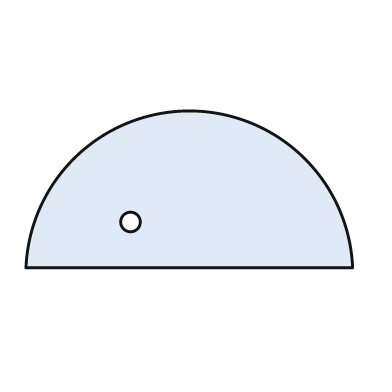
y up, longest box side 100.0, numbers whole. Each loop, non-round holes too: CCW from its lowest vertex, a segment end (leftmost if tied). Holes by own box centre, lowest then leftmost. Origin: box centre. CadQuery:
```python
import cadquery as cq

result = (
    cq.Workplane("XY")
    .moveTo(-50.0, -24.0)
    .lineTo(50.0, -24.0)
    .threePointArc((0.0, 24.0), (-50.0, -24.0))
    .close()
    .moveTo(-18.0, -10.0)
    .circle(3.0)
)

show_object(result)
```